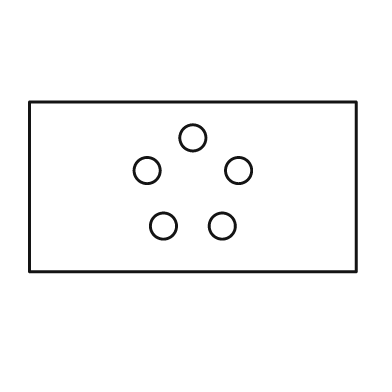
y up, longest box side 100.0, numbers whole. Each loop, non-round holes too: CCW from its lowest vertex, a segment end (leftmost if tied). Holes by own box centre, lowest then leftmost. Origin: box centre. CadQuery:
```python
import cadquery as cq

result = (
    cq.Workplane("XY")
    .moveTo(-50.0, -26.0)
    .lineTo(50.0, -26.0)
    .lineTo(50.0, 26.0)
    .lineTo(-50.0, 26.0)
    .close()
    .moveTo(-9.0, -12.0)
    .circle(4.0)
    .moveTo(9.0, -12.0)
    .circle(4.0)
    .moveTo(-14.0, 5.0)
    .circle(4.0)
    .moveTo(14.0, 5.0)
    .circle(4.0)
    .moveTo(0.0, 15.0)
    .circle(4.0)
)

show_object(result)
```